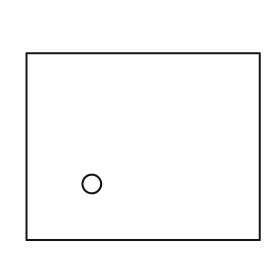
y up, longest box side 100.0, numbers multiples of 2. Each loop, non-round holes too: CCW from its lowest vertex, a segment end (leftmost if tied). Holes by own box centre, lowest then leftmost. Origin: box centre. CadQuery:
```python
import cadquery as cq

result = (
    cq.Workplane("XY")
    .moveTo(-50.0, -40.0)
    .lineTo(50.0, -40.0)
    .lineTo(50.0, 40.0)
    .lineTo(-50.0, 40.0)
    .close()
    .moveTo(-22.0, -16.0)
    .circle(4.0)
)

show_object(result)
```